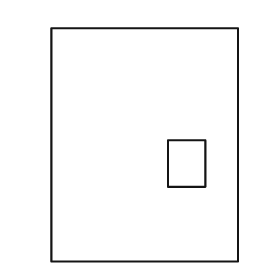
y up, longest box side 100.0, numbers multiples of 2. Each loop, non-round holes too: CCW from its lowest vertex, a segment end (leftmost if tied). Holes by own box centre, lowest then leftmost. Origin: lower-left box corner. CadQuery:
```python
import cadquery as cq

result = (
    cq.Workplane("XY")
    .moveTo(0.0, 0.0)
    .lineTo(80.0, 0.0)
    .lineTo(80.0, 100.0)
    .lineTo(0.0, 100.0)
    .close()
    .moveTo(50.0, 32.0)
    .lineTo(66.0, 32.0)
    .lineTo(66.0, 52.0)
    .lineTo(50.0, 52.0)
    .close()
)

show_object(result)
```